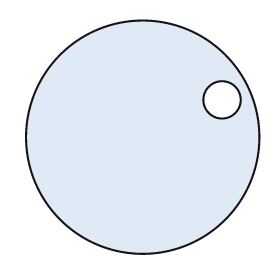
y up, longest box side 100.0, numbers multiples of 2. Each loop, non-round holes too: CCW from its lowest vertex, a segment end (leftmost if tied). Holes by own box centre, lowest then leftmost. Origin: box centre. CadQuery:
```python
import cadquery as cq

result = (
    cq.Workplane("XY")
    .moveTo(0.0, 0.0)
    .circle(50.0)
    .moveTo(34.0, 16.0)
    .circle(8.0)
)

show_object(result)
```